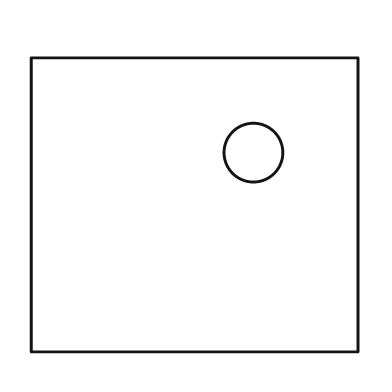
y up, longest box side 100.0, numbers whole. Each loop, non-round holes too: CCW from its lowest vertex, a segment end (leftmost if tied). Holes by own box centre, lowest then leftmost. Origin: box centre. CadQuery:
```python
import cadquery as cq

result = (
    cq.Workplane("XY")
    .moveTo(-50.0, -45.0)
    .lineTo(50.0, -45.0)
    .lineTo(50.0, 45.0)
    .lineTo(-50.0, 45.0)
    .close()
    .moveTo(18.0, 16.0)
    .circle(9.0)
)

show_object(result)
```